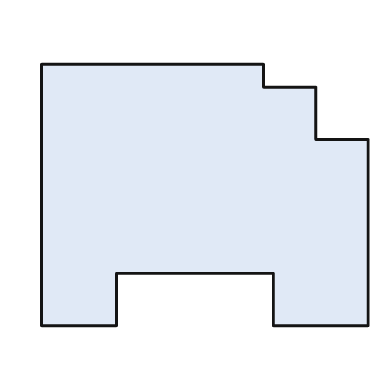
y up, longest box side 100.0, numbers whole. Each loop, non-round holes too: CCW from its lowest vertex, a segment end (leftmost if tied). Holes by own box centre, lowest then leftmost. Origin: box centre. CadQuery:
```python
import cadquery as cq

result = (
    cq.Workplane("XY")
    .moveTo(-50.0, -40.0)
    .lineTo(-27.0, -40.0)
    .lineTo(-27.0, -24.0)
    .lineTo(21.0, -24.0)
    .lineTo(21.0, -40.0)
    .lineTo(50.0, -40.0)
    .lineTo(50.0, 17.0)
    .lineTo(34.0, 17.0)
    .lineTo(34.0, 33.0)
    .lineTo(18.0, 33.0)
    .lineTo(18.0, 40.0)
    .lineTo(-50.0, 40.0)
    .close()
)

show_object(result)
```